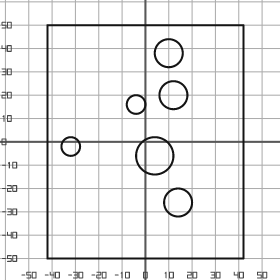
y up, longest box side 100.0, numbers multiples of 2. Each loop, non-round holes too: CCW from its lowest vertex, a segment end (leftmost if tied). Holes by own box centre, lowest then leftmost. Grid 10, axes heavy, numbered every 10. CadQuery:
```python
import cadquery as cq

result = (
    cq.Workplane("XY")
    .moveTo(-42.0, -50.0)
    .lineTo(42.0, -50.0)
    .lineTo(42.0, 50.0)
    .lineTo(-42.0, 50.0)
    .close()
    .moveTo(14.0, -26.0)
    .circle(6.0)
    .moveTo(4.0, -6.0)
    .circle(8.0)
    .moveTo(-32.0, -2.0)
    .circle(4.0)
    .moveTo(-4.0, 16.0)
    .circle(4.0)
    .moveTo(12.0, 20.0)
    .circle(6.0)
    .moveTo(10.0, 38.0)
    .circle(6.0)
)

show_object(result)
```